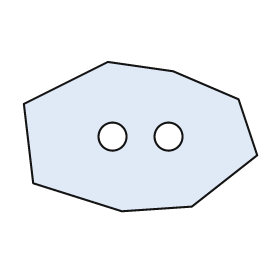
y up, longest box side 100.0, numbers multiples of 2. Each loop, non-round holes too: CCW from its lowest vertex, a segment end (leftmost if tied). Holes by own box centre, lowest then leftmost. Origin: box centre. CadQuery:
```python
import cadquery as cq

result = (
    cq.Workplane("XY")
    .moveTo(-8.0, -32.0)
    .lineTo(22.0, -30.0)
    .lineTo(50.0, -8.0)
    .lineTo(42.0, 16.0)
    .lineTo(14.0, 28.0)
    .lineTo(-14.0, 32.0)
    .lineTo(-50.0, 14.0)
    .lineTo(-46.0, -20.0)
    .close()
    .moveTo(-12.0, 0.0)
    .circle(6.0)
    .moveTo(12.0, 0.0)
    .circle(6.0)
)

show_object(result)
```